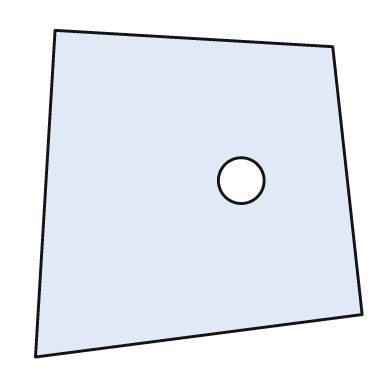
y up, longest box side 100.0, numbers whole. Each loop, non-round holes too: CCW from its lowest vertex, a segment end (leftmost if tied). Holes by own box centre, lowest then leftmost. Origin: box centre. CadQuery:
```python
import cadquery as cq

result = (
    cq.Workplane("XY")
    .moveTo(-50.0, -50.0)
    .lineTo(50.0, -37.0)
    .lineTo(41.0, 45.0)
    .lineTo(-44.0, 50.0)
    .close()
    .moveTo(13.0, 4.0)
    .circle(7.0)
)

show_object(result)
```